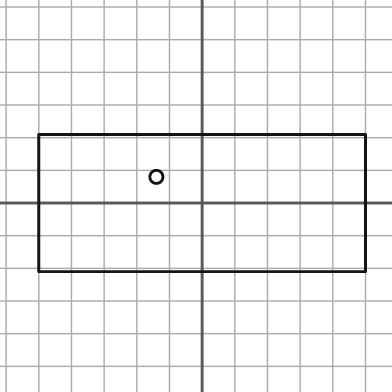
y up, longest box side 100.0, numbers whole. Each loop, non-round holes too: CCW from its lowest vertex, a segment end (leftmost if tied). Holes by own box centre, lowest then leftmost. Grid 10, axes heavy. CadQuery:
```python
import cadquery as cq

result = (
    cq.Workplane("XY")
    .moveTo(-50.0, -21.0)
    .lineTo(50.0, -21.0)
    .lineTo(50.0, 21.0)
    .lineTo(-50.0, 21.0)
    .close()
    .moveTo(-14.0, 8.0)
    .circle(2.0)
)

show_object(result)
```